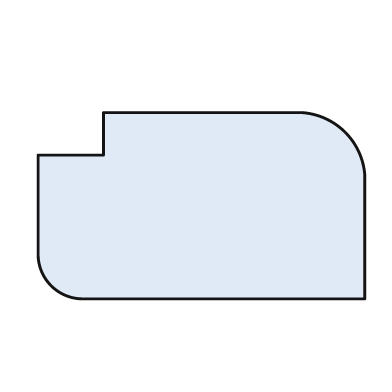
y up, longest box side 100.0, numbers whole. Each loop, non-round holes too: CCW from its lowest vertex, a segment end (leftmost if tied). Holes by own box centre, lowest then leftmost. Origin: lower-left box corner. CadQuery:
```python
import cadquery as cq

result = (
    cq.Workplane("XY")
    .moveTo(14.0, 0.0)
    .lineTo(100.0, 0.0)
    .lineTo(100.0, 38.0)
    .threePointArc((94.0, 51.0), (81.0, 57.0))
    .lineTo(20.0, 57.0)
    .lineTo(20.0, 44.0)
    .lineTo(0.0, 44.0)
    .lineTo(0.0, 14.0)
    .threePointArc((4.0, 4.0), (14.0, 0.0))
    .close()
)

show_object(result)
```